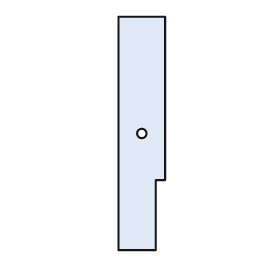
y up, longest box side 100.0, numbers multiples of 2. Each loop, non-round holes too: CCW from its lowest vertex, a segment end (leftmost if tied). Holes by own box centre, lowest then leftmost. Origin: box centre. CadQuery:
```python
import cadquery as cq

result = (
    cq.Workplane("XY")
    .moveTo(-10.0, -50.0)
    .lineTo(6.0, -50.0)
    .lineTo(6.0, -20.0)
    .lineTo(10.0, -20.0)
    .lineTo(10.0, 50.0)
    .lineTo(-10.0, 50.0)
    .close()
    .moveTo(0.0, 0.0)
    .circle(2.0)
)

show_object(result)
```